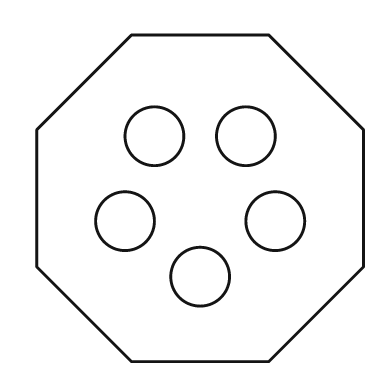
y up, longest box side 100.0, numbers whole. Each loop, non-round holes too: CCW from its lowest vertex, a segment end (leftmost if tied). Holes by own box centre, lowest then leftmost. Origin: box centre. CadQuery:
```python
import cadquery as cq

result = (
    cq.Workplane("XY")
    .moveTo(-21.0, -50.0)
    .lineTo(21.0, -50.0)
    .lineTo(50.0, -21.0)
    .lineTo(50.0, 21.0)
    .lineTo(21.0, 50.0)
    .lineTo(-21.0, 50.0)
    .lineTo(-50.0, 21.0)
    .lineTo(-50.0, -21.0)
    .close()
    .moveTo(0.0, -24.0)
    .circle(9.0)
    .moveTo(-23.0, -7.0)
    .circle(9.0)
    .moveTo(23.0, -7.0)
    .circle(9.0)
    .moveTo(-14.0, 19.0)
    .circle(9.0)
    .moveTo(14.0, 19.0)
    .circle(9.0)
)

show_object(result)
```